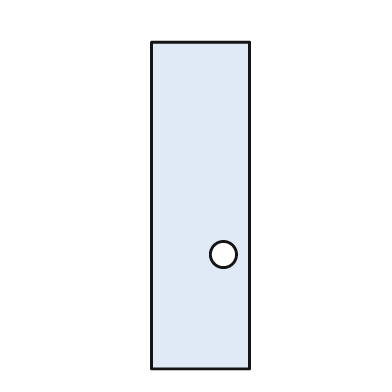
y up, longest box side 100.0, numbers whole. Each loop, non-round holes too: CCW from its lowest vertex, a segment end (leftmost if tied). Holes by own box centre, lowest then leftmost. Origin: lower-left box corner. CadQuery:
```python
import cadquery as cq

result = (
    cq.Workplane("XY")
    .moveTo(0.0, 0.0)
    .lineTo(30.0, 0.0)
    .lineTo(30.0, 100.0)
    .lineTo(0.0, 100.0)
    .close()
    .moveTo(22.0, 35.0)
    .circle(4.0)
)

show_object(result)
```